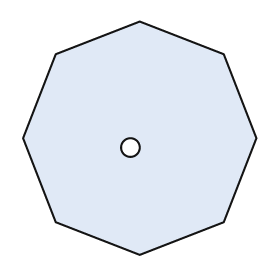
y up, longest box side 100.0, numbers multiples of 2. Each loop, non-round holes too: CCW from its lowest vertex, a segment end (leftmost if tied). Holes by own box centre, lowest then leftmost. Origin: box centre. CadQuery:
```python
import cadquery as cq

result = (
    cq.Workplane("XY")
    .moveTo(0.0, -50.0)
    .lineTo(36.0, -36.0)
    .lineTo(50.0, 0.0)
    .lineTo(36.0, 36.0)
    .lineTo(0.0, 50.0)
    .lineTo(-36.0, 36.0)
    .lineTo(-50.0, 0.0)
    .lineTo(-36.0, -36.0)
    .close()
    .moveTo(-4.0, -4.0)
    .circle(4.0)
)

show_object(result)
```